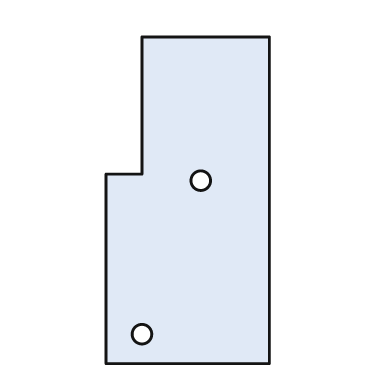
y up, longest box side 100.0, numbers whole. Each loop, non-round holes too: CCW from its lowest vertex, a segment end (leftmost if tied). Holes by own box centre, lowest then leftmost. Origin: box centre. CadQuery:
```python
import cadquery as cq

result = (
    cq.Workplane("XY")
    .moveTo(-25.0, -50.0)
    .lineTo(25.0, -50.0)
    .lineTo(25.0, 50.0)
    .lineTo(-14.0, 50.0)
    .lineTo(-14.0, 8.0)
    .lineTo(-25.0, 8.0)
    .close()
    .moveTo(-14.0, -41.0)
    .circle(3.0)
    .moveTo(4.0, 6.0)
    .circle(3.0)
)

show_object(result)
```